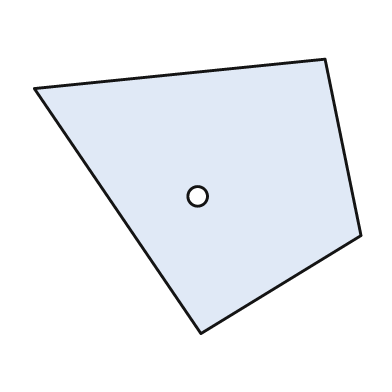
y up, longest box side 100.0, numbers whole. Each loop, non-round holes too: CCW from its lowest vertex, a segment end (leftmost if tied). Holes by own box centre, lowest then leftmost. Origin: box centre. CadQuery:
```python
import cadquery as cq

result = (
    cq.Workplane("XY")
    .moveTo(1.0, -42.0)
    .lineTo(50.0, -12.0)
    .lineTo(39.0, 42.0)
    .lineTo(-50.0, 33.0)
    .close()
    .moveTo(0.0, 0.0)
    .circle(3.0)
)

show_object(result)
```